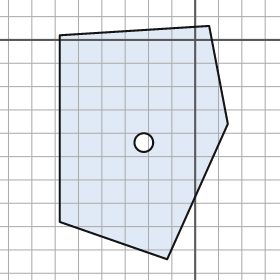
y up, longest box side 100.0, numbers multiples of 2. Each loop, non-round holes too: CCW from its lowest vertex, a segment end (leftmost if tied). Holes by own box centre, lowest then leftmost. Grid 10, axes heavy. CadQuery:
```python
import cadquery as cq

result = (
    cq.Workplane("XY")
    .moveTo(-12.0, -94.0)
    .lineTo(14.0, -36.0)
    .lineTo(6.0, 6.0)
    .lineTo(-58.0, 2.0)
    .lineTo(-58.0, -78.0)
    .close()
    .moveTo(-22.0, -44.0)
    .circle(4.0)
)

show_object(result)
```